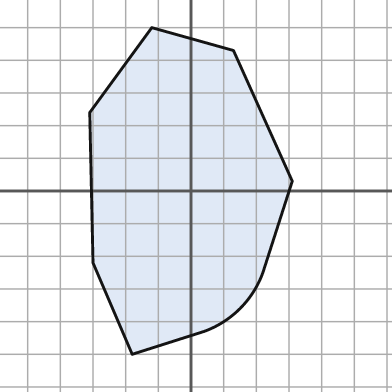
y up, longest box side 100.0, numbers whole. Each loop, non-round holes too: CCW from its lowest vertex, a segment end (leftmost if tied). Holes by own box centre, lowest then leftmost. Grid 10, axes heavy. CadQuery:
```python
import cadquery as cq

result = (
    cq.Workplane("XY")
    .moveTo(-18.0, -50.0)
    .lineTo(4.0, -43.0)
    .threePointArc((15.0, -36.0), (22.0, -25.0))
    .lineTo(31.0, 3.0)
    .lineTo(13.0, 43.0)
    .lineTo(-12.0, 50.0)
    .lineTo(-31.0, 24.0)
    .lineTo(-30.0, -22.0)
    .close()
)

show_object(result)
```